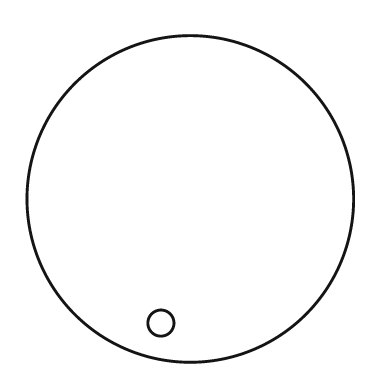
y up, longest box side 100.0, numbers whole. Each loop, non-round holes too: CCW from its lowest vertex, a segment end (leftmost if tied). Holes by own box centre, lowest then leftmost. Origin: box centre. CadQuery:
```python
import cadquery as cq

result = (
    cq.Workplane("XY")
    .moveTo(0.0, 0.0)
    .circle(50.0)
    .moveTo(-9.0, -38.0)
    .circle(4.0)
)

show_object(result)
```